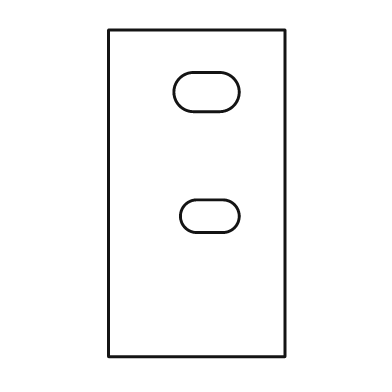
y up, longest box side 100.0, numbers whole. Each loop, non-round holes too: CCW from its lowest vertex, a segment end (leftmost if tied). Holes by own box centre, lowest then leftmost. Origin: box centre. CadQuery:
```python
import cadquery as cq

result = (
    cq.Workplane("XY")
    .moveTo(-27.0, -50.0)
    .lineTo(27.0, -50.0)
    .lineTo(27.0, 50.0)
    .lineTo(-27.0, 50.0)
    .close()
    .moveTo(0.0, -12.0)
    .lineTo(8.0, -12.0)
    .threePointArc((13.0, -7.0), (8.0, -2.0))
    .lineTo(0.0, -2.0)
    .threePointArc((-5.0, -7.0), (0.0, -12.0))
    .close()
    .moveTo(-1.0, 25.0)
    .lineTo(7.0, 25.0)
    .threePointArc((13.0, 31.0), (7.0, 37.0))
    .lineTo(-1.0, 37.0)
    .threePointArc((-7.0, 31.0), (-1.0, 25.0))
    .close()
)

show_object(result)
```